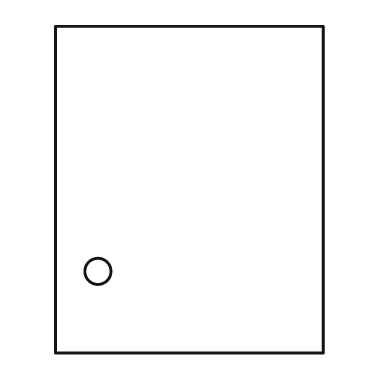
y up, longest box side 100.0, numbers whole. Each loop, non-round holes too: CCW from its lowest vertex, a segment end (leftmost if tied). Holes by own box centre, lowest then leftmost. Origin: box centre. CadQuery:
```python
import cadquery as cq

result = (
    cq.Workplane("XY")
    .moveTo(-41.0, -50.0)
    .lineTo(41.0, -50.0)
    .lineTo(41.0, 50.0)
    .lineTo(-41.0, 50.0)
    .close()
    .moveTo(-28.0, -25.0)
    .circle(4.0)
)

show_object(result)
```